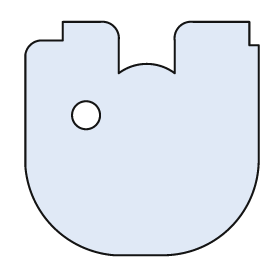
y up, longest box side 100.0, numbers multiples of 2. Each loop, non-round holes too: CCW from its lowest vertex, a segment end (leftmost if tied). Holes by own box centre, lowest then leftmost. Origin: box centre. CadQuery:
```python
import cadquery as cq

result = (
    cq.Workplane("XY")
    .moveTo(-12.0, -50.0)
    .lineTo(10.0, -50.0)
    .threePointArc((38.0, -38.0), (50.0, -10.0))
    .lineTo(50.0, 40.0)
    .lineTo(46.0, 40.0)
    .lineTo(46.0, 50.0)
    .lineTo(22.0, 50.0)
    .threePointArc((16.0, 48.0), (14.0, 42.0))
    .lineTo(14.0, 28.0)
    .threePointArc((2.0, 32.0), (-10.0, 28.0))
    .lineTo(-10.0, 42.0)
    .threePointArc((-12.0, 48.0), (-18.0, 50.0))
    .lineTo(-34.0, 50.0)
    .lineTo(-34.0, 42.0)
    .lineTo(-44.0, 42.0)
    .threePointArc((-48.0, 40.0), (-50.0, 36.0))
    .lineTo(-50.0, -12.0)
    .threePointArc((-38.0, -38.0), (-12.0, -50.0))
    .close()
    .moveTo(-24.0, 10.0)
    .circle(6.0)
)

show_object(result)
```